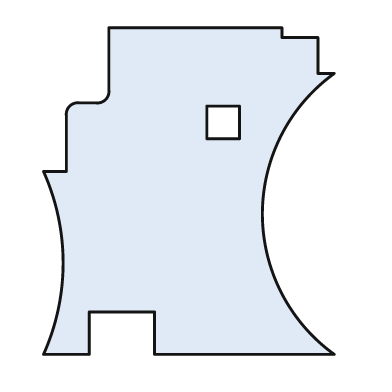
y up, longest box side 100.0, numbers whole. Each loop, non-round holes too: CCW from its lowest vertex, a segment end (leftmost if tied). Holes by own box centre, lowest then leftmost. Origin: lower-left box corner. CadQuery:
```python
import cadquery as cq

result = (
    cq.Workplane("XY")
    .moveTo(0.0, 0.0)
    .lineTo(14.0, 0.0)
    .lineTo(14.0, 13.0)
    .lineTo(34.0, 13.0)
    .lineTo(34.0, 0.0)
    .lineTo(89.0, 0.0)
    .threePointArc((67.0, 43.0), (89.0, 86.0))
    .lineTo(84.0, 86.0)
    .lineTo(84.0, 97.0)
    .lineTo(73.0, 97.0)
    .lineTo(73.0, 100.0)
    .lineTo(20.0, 100.0)
    .lineTo(20.0, 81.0)
    .threePointArc((19.0, 78.0), (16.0, 77.0))
    .lineTo(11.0, 77.0)
    .threePointArc((8.0, 76.0), (7.0, 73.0))
    .lineTo(7.0, 56.0)
    .lineTo(0.0, 56.0)
    .threePointArc((6.0, 28.0), (0.0, 0.0))
    .close()
    .moveTo(50.0, 66.0)
    .lineTo(60.0, 66.0)
    .lineTo(60.0, 76.0)
    .lineTo(50.0, 76.0)
    .close()
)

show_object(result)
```